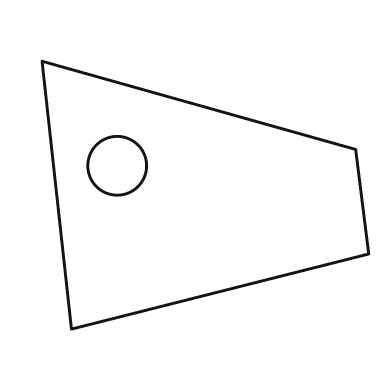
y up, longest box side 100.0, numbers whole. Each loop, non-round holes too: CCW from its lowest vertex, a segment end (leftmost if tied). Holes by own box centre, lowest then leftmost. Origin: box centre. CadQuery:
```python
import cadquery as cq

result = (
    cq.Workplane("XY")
    .moveTo(-41.0, -41.0)
    .lineTo(50.0, -18.0)
    .lineTo(46.0, 14.0)
    .lineTo(-50.0, 41.0)
    .close()
    .moveTo(-27.0, 9.0)
    .circle(9.0)
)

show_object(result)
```